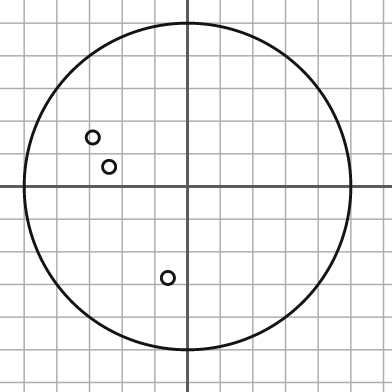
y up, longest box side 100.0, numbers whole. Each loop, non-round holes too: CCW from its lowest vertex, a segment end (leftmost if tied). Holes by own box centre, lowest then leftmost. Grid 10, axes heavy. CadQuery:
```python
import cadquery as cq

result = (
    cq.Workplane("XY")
    .moveTo(0.0, 0.0)
    .circle(50.0)
    .moveTo(-6.0, -28.0)
    .circle(2.0)
    .moveTo(-24.0, 6.0)
    .circle(2.0)
    .moveTo(-29.0, 15.0)
    .circle(2.0)
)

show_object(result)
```